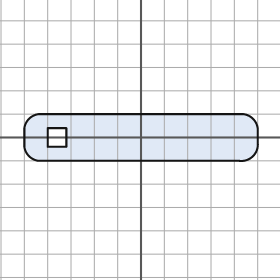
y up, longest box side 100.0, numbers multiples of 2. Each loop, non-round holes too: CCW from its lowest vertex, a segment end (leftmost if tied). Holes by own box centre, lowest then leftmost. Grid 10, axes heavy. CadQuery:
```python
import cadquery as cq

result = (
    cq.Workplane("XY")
    .moveTo(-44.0, -10.0)
    .lineTo(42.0, -10.0)
    .threePointArc((48.0, -8.0), (50.0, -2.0))
    .lineTo(50.0, 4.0)
    .threePointArc((48.0, 8.0), (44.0, 10.0))
    .lineTo(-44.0, 10.0)
    .threePointArc((-48.0, 8.0), (-50.0, 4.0))
    .lineTo(-50.0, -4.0)
    .threePointArc((-48.0, -8.0), (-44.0, -10.0))
    .close()
    .moveTo(-40.0, -4.0)
    .lineTo(-32.0, -4.0)
    .lineTo(-32.0, 4.0)
    .lineTo(-40.0, 4.0)
    .close()
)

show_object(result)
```